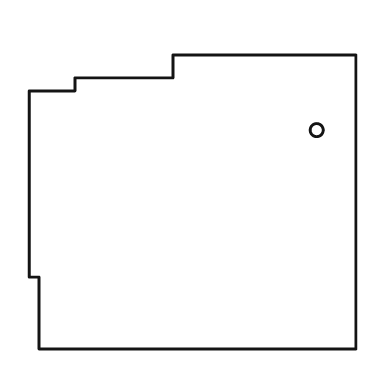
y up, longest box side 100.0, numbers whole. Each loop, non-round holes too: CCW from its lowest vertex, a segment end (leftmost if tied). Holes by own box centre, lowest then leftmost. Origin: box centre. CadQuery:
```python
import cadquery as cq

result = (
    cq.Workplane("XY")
    .moveTo(-47.0, -45.0)
    .lineTo(50.0, -45.0)
    .lineTo(50.0, 45.0)
    .lineTo(-6.0, 45.0)
    .lineTo(-6.0, 38.0)
    .lineTo(-36.0, 38.0)
    .lineTo(-36.0, 34.0)
    .lineTo(-50.0, 34.0)
    .lineTo(-50.0, -23.0)
    .lineTo(-47.0, -23.0)
    .close()
    .moveTo(38.0, 22.0)
    .circle(2.0)
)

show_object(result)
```